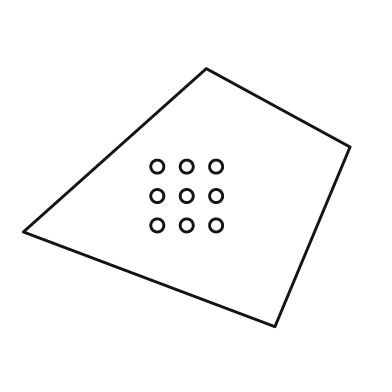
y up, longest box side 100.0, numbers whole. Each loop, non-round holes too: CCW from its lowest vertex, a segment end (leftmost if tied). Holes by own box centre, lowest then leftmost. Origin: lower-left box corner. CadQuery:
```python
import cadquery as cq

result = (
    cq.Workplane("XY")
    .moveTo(77.0, 0.0)
    .lineTo(100.0, 55.0)
    .lineTo(56.0, 79.0)
    .lineTo(0.0, 29.0)
    .close()
    .moveTo(41.0, 31.0)
    .circle(2.0)
    .moveTo(50.0, 31.0)
    .circle(2.0)
    .moveTo(59.0, 31.0)
    .circle(2.0)
    .moveTo(41.0, 40.0)
    .circle(2.0)
    .moveTo(50.0, 40.0)
    .circle(2.0)
    .moveTo(59.0, 40.0)
    .circle(2.0)
    .moveTo(41.0, 49.0)
    .circle(2.0)
    .moveTo(50.0, 49.0)
    .circle(2.0)
    .moveTo(59.0, 49.0)
    .circle(2.0)
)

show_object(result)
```